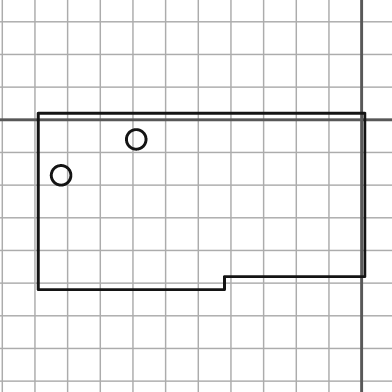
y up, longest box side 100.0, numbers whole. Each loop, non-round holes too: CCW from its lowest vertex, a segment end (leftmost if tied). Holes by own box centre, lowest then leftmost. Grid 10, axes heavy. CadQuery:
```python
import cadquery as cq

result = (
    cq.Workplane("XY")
    .moveTo(-99.0, -52.0)
    .lineTo(-42.0, -52.0)
    .lineTo(-42.0, -48.0)
    .lineTo(1.0, -48.0)
    .lineTo(1.0, 2.0)
    .lineTo(-99.0, 2.0)
    .close()
    .moveTo(-92.0, -17.0)
    .circle(3.0)
    .moveTo(-69.0, -6.0)
    .circle(3.0)
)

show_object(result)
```